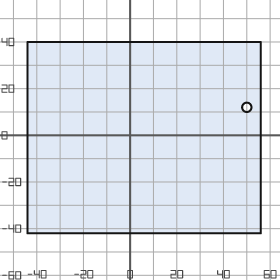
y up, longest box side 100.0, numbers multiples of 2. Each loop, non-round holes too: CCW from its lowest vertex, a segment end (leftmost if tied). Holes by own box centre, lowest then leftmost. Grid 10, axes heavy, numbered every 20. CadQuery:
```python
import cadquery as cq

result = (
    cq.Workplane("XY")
    .moveTo(-44.0, -42.0)
    .lineTo(56.0, -42.0)
    .lineTo(56.0, 40.0)
    .lineTo(-44.0, 40.0)
    .close()
    .moveTo(50.0, 12.0)
    .circle(2.0)
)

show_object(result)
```